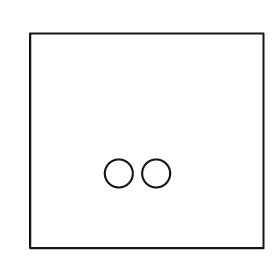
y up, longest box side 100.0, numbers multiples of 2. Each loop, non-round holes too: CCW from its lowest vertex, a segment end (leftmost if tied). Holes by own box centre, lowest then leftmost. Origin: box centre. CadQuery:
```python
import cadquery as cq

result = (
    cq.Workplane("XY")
    .moveTo(-50.0, -46.0)
    .lineTo(50.0, -46.0)
    .lineTo(50.0, 46.0)
    .lineTo(-50.0, 46.0)
    .close()
    .moveTo(-12.0, -14.0)
    .circle(6.0)
    .moveTo(4.0, -14.0)
    .circle(6.0)
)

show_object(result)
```